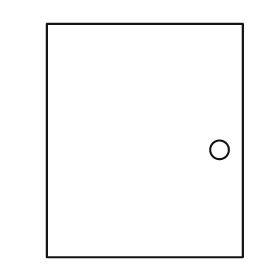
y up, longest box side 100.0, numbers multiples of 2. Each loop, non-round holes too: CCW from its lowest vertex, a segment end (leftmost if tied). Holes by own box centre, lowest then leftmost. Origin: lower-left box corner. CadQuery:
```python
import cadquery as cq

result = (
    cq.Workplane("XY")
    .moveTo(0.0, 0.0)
    .lineTo(84.0, 0.0)
    .lineTo(84.0, 100.0)
    .lineTo(0.0, 100.0)
    .close()
    .moveTo(74.0, 46.0)
    .circle(4.0)
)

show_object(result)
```